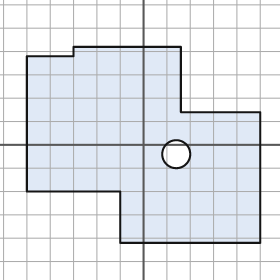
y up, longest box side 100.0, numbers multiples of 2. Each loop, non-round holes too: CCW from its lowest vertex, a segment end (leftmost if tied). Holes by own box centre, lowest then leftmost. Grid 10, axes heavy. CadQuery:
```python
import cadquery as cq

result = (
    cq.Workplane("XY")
    .moveTo(-10.0, -42.0)
    .lineTo(50.0, -42.0)
    .lineTo(50.0, 14.0)
    .lineTo(16.0, 14.0)
    .lineTo(16.0, 42.0)
    .lineTo(-30.0, 42.0)
    .lineTo(-30.0, 38.0)
    .lineTo(-50.0, 38.0)
    .lineTo(-50.0, -20.0)
    .lineTo(-10.0, -20.0)
    .close()
    .moveTo(14.0, -4.0)
    .circle(6.0)
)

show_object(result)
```